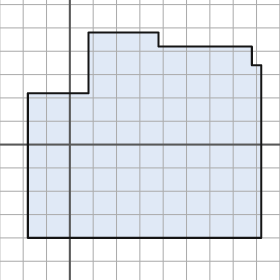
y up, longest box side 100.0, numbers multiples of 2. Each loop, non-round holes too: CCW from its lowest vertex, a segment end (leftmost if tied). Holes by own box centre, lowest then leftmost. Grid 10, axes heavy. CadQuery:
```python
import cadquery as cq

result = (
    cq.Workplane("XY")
    .moveTo(-18.0, -40.0)
    .lineTo(82.0, -40.0)
    .lineTo(82.0, 34.0)
    .lineTo(78.0, 34.0)
    .lineTo(78.0, 42.0)
    .lineTo(38.0, 42.0)
    .lineTo(38.0, 48.0)
    .lineTo(8.0, 48.0)
    .lineTo(8.0, 22.0)
    .lineTo(-18.0, 22.0)
    .close()
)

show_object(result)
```